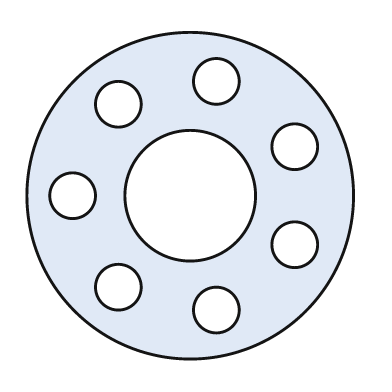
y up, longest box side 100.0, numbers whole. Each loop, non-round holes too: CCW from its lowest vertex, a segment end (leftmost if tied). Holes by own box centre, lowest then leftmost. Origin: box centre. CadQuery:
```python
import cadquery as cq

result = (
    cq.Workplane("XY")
    .moveTo(0.0, 0.0)
    .circle(50.0)
    .moveTo(8.0, -35.0)
    .circle(7.0)
    .moveTo(-22.0, -28.0)
    .circle(7.0)
    .moveTo(32.0, -15.0)
    .circle(7.0)
    .moveTo(-36.0, 0.0)
    .circle(7.0)
    .moveTo(0.0, 0.0)
    .circle(20.0)
    .moveTo(32.0, 15.0)
    .circle(7.0)
    .moveTo(-22.0, 28.0)
    .circle(7.0)
    .moveTo(8.0, 35.0)
    .circle(7.0)
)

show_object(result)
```